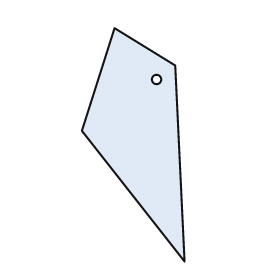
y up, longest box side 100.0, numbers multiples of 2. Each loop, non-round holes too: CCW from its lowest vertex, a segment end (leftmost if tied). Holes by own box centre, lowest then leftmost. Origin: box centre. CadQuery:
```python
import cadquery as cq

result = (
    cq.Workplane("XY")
    .moveTo(22.0, -50.0)
    .lineTo(18.0, 34.0)
    .lineTo(-8.0, 50.0)
    .lineTo(-22.0, 6.0)
    .close()
    .moveTo(10.0, 28.0)
    .circle(2.0)
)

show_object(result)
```